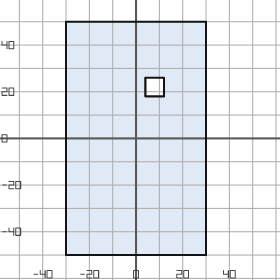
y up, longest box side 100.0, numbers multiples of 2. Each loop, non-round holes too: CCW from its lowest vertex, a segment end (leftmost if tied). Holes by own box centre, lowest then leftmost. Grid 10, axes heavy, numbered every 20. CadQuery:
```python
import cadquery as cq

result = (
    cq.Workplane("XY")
    .moveTo(-30.0, -50.0)
    .lineTo(30.0, -50.0)
    .lineTo(30.0, 50.0)
    .lineTo(-30.0, 50.0)
    .close()
    .moveTo(4.0, 18.0)
    .lineTo(12.0, 18.0)
    .lineTo(12.0, 26.0)
    .lineTo(4.0, 26.0)
    .close()
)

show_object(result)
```